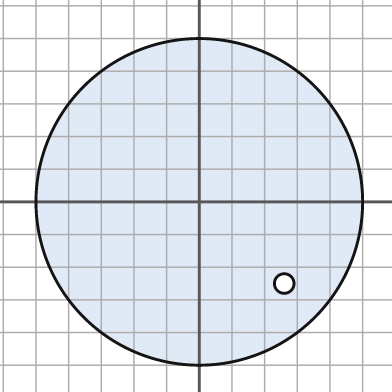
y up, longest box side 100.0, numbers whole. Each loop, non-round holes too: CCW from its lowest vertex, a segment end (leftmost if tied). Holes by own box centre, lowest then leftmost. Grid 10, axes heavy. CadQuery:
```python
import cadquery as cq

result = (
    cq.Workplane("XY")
    .moveTo(0.0, 0.0)
    .circle(50.0)
    .moveTo(26.0, -25.0)
    .circle(3.0)
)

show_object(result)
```